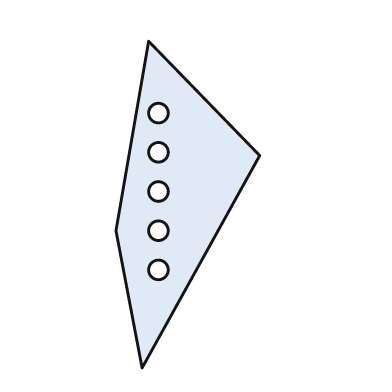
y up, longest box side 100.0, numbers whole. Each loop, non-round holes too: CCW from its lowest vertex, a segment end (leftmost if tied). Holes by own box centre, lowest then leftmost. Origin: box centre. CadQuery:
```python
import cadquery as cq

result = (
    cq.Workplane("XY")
    .moveTo(-14.0, -50.0)
    .lineTo(22.0, 15.0)
    .lineTo(-12.0, 50.0)
    .lineTo(-22.0, -8.0)
    .close()
    .moveTo(-9.0, -20.0)
    .circle(3.0)
    .moveTo(-9.0, -8.0)
    .circle(3.0)
    .moveTo(-9.0, 4.0)
    .circle(3.0)
    .moveTo(-9.0, 16.0)
    .circle(3.0)
    .moveTo(-9.0, 28.0)
    .circle(3.0)
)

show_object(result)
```